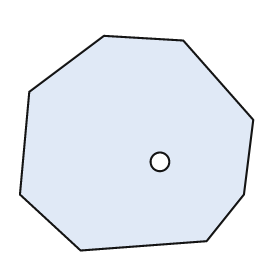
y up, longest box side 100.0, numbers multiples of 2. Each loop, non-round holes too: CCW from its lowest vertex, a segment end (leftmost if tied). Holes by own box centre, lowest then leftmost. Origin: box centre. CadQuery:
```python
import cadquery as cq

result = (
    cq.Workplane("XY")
    .moveTo(-24.0, -46.0)
    .lineTo(30.0, -42.0)
    .lineTo(46.0, -22.0)
    .lineTo(50.0, 10.0)
    .lineTo(20.0, 44.0)
    .lineTo(-14.0, 46.0)
    .lineTo(-46.0, 22.0)
    .lineTo(-50.0, -22.0)
    .close()
    .moveTo(10.0, -8.0)
    .circle(4.0)
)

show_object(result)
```